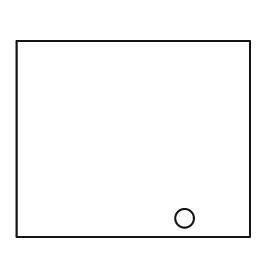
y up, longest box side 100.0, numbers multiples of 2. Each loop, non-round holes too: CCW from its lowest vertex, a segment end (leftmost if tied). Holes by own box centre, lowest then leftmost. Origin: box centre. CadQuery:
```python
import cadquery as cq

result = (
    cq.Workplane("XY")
    .moveTo(-50.0, -42.0)
    .lineTo(50.0, -42.0)
    .lineTo(50.0, 42.0)
    .lineTo(-50.0, 42.0)
    .close()
    .moveTo(22.0, -34.0)
    .circle(4.0)
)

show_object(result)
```